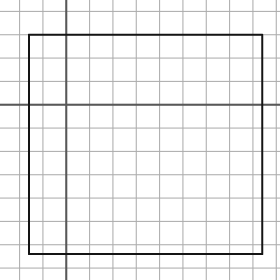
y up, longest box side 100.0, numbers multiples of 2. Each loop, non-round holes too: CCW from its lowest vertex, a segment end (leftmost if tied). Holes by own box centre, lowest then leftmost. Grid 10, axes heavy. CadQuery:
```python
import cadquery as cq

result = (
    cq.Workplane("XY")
    .moveTo(-16.0, -64.0)
    .lineTo(84.0, -64.0)
    .lineTo(84.0, 30.0)
    .lineTo(-16.0, 30.0)
    .close()
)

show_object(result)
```